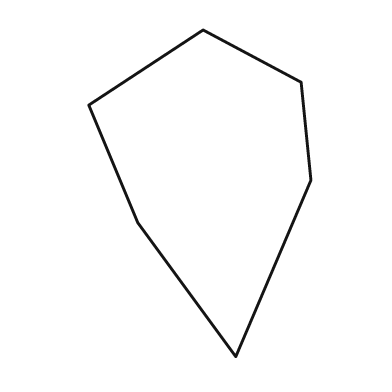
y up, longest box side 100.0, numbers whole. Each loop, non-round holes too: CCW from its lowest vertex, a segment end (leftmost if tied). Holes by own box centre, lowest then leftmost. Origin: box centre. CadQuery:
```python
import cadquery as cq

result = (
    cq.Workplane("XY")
    .moveTo(11.0, -50.0)
    .lineTo(34.0, 4.0)
    .lineTo(31.0, 34.0)
    .lineTo(1.0, 50.0)
    .lineTo(-34.0, 27.0)
    .lineTo(-19.0, -9.0)
    .close()
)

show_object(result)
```